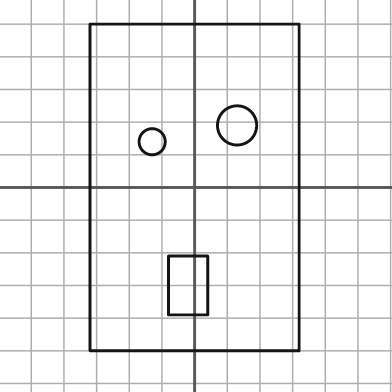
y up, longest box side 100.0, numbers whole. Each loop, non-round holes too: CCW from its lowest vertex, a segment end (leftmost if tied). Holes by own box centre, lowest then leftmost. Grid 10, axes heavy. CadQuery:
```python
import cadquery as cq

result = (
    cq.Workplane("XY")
    .moveTo(-32.0, -50.0)
    .lineTo(32.0, -50.0)
    .lineTo(32.0, 50.0)
    .lineTo(-32.0, 50.0)
    .close()
    .moveTo(-8.0, -39.0)
    .lineTo(4.0, -39.0)
    .lineTo(4.0, -21.0)
    .lineTo(-8.0, -21.0)
    .close()
    .moveTo(-13.0, 14.0)
    .circle(4.0)
    .moveTo(13.0, 19.0)
    .circle(6.0)
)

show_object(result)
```